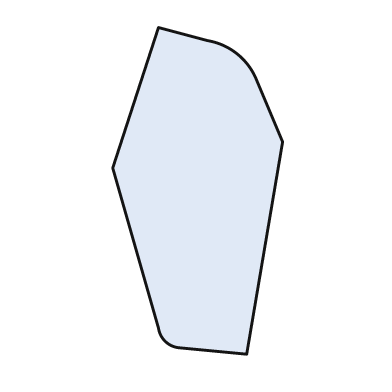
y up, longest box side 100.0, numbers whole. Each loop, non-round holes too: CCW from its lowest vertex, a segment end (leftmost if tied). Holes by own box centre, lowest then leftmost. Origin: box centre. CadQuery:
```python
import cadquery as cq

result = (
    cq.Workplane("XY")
    .moveTo(15.0, -50.0)
    .lineTo(26.0, 15.0)
    .lineTo(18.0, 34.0)
    .threePointArc((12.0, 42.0), (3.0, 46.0))
    .lineTo(-12.0, 50.0)
    .lineTo(-26.0, 7.0)
    .lineTo(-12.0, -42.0)
    .threePointArc((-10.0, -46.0), (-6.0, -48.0))
    .close()
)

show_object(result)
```